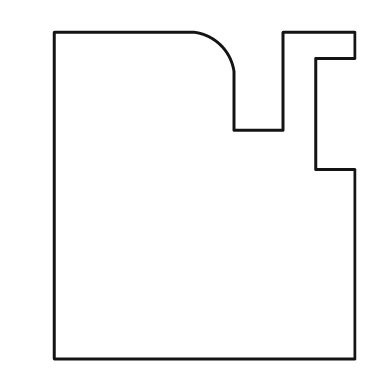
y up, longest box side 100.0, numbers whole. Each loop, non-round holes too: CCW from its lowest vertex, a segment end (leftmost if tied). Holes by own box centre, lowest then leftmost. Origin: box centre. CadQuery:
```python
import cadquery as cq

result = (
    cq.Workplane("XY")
    .moveTo(-46.0, -50.0)
    .lineTo(46.0, -50.0)
    .lineTo(46.0, 8.0)
    .lineTo(34.0, 8.0)
    .lineTo(34.0, 42.0)
    .lineTo(46.0, 42.0)
    .lineTo(46.0, 50.0)
    .lineTo(24.0, 50.0)
    .lineTo(24.0, 20.0)
    .lineTo(9.0, 20.0)
    .lineTo(9.0, 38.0)
    .threePointArc((5.0, 46.0), (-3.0, 50.0))
    .lineTo(-46.0, 50.0)
    .close()
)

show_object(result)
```